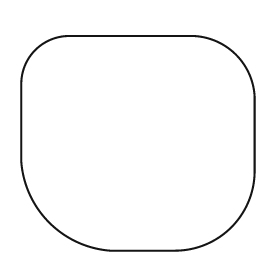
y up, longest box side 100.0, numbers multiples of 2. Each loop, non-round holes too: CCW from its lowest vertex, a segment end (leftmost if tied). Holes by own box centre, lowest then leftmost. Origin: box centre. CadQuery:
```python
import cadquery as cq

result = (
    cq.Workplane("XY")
    .moveTo(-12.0, -46.0)
    .lineTo(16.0, -46.0)
    .threePointArc((40.0, -36.0), (50.0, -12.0))
    .lineTo(50.0, 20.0)
    .threePointArc((42.0, 38.0), (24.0, 46.0))
    .lineTo(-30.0, 46.0)
    .threePointArc((-44.0, 40.0), (-50.0, 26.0))
    .lineTo(-50.0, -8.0)
    .threePointArc((-38.0, -34.0), (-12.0, -46.0))
    .close()
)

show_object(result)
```